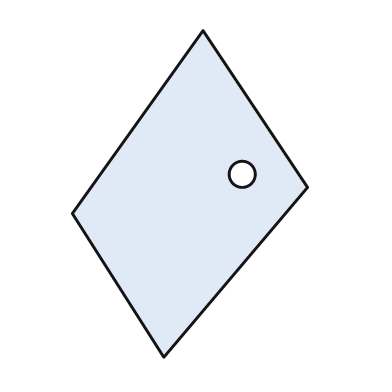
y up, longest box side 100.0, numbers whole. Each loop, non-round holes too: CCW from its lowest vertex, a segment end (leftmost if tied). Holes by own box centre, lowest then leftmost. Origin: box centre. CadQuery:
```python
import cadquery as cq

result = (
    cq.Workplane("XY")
    .moveTo(-8.0, -50.0)
    .lineTo(36.0, 2.0)
    .lineTo(4.0, 50.0)
    .lineTo(-36.0, -6.0)
    .close()
    .moveTo(16.0, 6.0)
    .circle(4.0)
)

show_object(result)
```